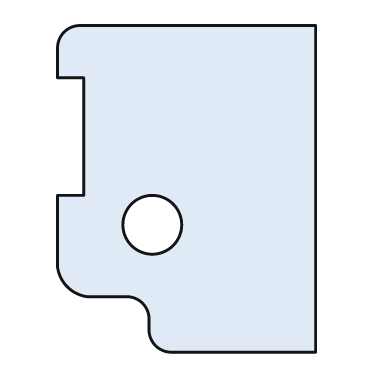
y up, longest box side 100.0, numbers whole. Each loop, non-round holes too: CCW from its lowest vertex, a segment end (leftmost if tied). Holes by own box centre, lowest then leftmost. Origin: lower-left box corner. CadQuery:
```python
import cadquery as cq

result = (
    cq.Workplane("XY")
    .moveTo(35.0, 0.0)
    .lineTo(79.0, 0.0)
    .lineTo(79.0, 100.0)
    .lineTo(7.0, 100.0)
    .threePointArc((2.0, 98.0), (0.0, 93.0))
    .lineTo(0.0, 84.0)
    .lineTo(8.0, 84.0)
    .lineTo(8.0, 48.0)
    .lineTo(0.0, 48.0)
    .lineTo(0.0, 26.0)
    .threePointArc((3.0, 20.0), (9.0, 17.0))
    .lineTo(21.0, 17.0)
    .threePointArc((26.0, 15.0), (28.0, 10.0))
    .lineTo(28.0, 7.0)
    .threePointArc((30.0, 2.0), (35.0, 0.0))
    .close()
    .moveTo(29.0, 39.0)
    .circle(9.0)
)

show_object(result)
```